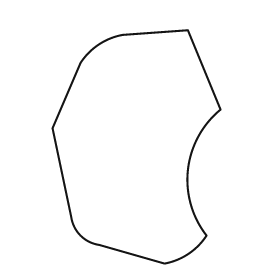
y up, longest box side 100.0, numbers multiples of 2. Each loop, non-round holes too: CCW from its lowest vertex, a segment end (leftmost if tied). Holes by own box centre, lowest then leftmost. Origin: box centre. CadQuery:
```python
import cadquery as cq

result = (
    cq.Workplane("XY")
    .moveTo(12.0, -50.0)
    .threePointArc((22.0, -46.0), (30.0, -38.0))
    .threePointArc((22.0, -10.0), (36.0, 16.0))
    .lineTo(22.0, 50.0)
    .lineTo(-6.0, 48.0)
    .threePointArc((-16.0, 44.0), (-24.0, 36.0))
    .lineTo(-36.0, 8.0)
    .lineTo(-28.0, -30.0)
    .threePointArc((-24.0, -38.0), (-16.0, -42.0))
    .close()
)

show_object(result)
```